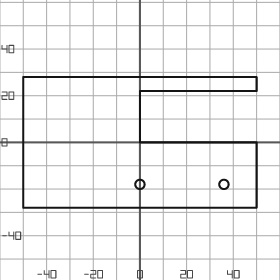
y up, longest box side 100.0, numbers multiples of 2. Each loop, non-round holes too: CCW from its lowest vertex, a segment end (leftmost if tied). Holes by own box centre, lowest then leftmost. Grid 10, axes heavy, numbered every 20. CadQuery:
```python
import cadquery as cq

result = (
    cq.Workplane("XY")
    .moveTo(-50.0, -28.0)
    .lineTo(50.0, -28.0)
    .lineTo(50.0, 0.0)
    .lineTo(0.0, 0.0)
    .lineTo(0.0, 22.0)
    .lineTo(50.0, 22.0)
    .lineTo(50.0, 28.0)
    .lineTo(-50.0, 28.0)
    .close()
    .moveTo(0.0, -18.0)
    .circle(2.0)
    .moveTo(36.0, -18.0)
    .circle(2.0)
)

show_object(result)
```